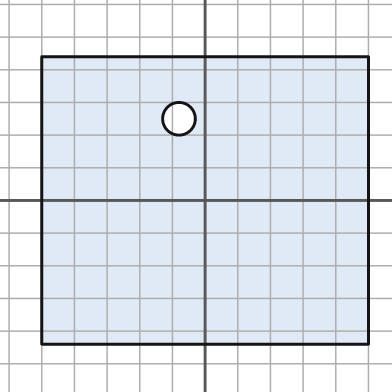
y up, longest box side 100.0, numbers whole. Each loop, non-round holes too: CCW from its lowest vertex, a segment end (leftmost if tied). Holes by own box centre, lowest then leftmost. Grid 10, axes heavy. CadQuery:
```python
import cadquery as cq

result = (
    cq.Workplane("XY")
    .moveTo(-50.0, -44.0)
    .lineTo(50.0, -44.0)
    .lineTo(50.0, 44.0)
    .lineTo(-50.0, 44.0)
    .close()
    .moveTo(-8.0, 25.0)
    .circle(5.0)
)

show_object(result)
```